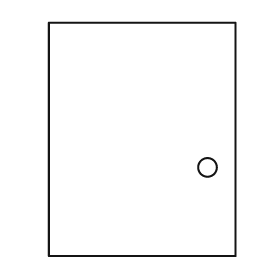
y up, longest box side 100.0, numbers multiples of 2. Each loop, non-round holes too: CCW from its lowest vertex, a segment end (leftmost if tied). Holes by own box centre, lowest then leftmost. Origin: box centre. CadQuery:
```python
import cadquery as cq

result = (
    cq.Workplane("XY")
    .moveTo(-40.0, -50.0)
    .lineTo(40.0, -50.0)
    .lineTo(40.0, 50.0)
    .lineTo(-40.0, 50.0)
    .close()
    .moveTo(28.0, -12.0)
    .circle(4.0)
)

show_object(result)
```